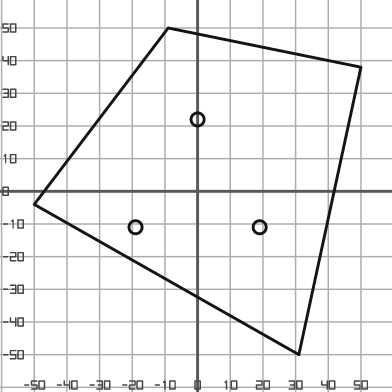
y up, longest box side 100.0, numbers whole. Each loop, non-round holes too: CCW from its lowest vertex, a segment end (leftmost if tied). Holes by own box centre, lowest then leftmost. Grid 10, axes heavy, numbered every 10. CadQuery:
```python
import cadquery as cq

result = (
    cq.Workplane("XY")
    .moveTo(31.0, -50.0)
    .lineTo(50.0, 38.0)
    .lineTo(-9.0, 50.0)
    .lineTo(-50.0, -4.0)
    .close()
    .moveTo(-19.0, -11.0)
    .circle(2.0)
    .moveTo(19.0, -11.0)
    .circle(2.0)
    .moveTo(0.0, 22.0)
    .circle(2.0)
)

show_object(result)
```